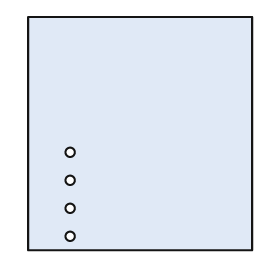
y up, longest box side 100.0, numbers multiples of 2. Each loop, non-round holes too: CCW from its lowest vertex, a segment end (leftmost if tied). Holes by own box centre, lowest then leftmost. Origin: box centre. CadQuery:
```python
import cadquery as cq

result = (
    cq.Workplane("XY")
    .moveTo(-48.0, -50.0)
    .lineTo(48.0, -50.0)
    .lineTo(48.0, 50.0)
    .lineTo(-48.0, 50.0)
    .close()
    .moveTo(-30.0, -44.0)
    .circle(2.0)
    .moveTo(-30.0, -32.0)
    .circle(2.0)
    .moveTo(-30.0, -20.0)
    .circle(2.0)
    .moveTo(-30.0, -8.0)
    .circle(2.0)
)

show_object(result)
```